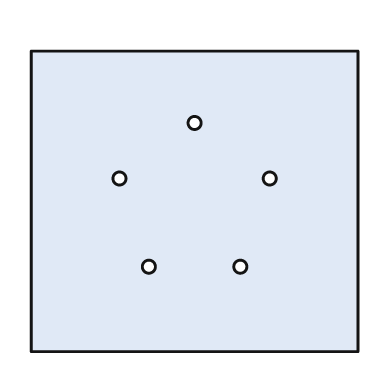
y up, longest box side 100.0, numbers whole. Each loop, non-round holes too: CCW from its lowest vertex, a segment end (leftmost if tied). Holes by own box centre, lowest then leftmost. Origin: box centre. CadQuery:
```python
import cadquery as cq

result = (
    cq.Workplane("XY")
    .moveTo(-50.0, -46.0)
    .lineTo(50.0, -46.0)
    .lineTo(50.0, 46.0)
    .lineTo(-50.0, 46.0)
    .close()
    .moveTo(-14.0, -20.0)
    .circle(2.0)
    .moveTo(14.0, -20.0)
    .circle(2.0)
    .moveTo(-23.0, 7.0)
    .circle(2.0)
    .moveTo(23.0, 7.0)
    .circle(2.0)
    .moveTo(0.0, 24.0)
    .circle(2.0)
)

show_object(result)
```